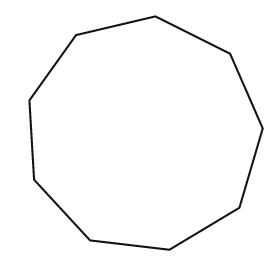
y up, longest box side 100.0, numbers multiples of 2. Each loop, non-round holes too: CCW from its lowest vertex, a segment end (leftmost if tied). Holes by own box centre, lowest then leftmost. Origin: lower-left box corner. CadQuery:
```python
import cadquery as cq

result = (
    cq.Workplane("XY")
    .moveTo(60.0, 0.0)
    .lineTo(90.0, 18.0)
    .lineTo(100.0, 52.0)
    .lineTo(86.0, 84.0)
    .lineTo(54.0, 100.0)
    .lineTo(20.0, 92.0)
    .lineTo(0.0, 64.0)
    .lineTo(2.0, 30.0)
    .lineTo(26.0, 4.0)
    .close()
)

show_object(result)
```